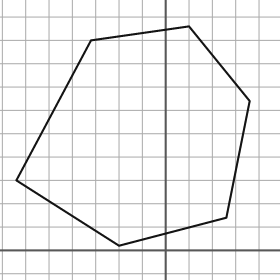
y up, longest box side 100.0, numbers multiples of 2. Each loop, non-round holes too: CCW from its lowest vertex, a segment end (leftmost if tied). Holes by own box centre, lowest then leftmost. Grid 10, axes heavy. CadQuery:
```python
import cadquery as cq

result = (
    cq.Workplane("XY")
    .moveTo(-20.0, 2.0)
    .lineTo(26.0, 14.0)
    .lineTo(36.0, 64.0)
    .lineTo(10.0, 96.0)
    .lineTo(-32.0, 90.0)
    .lineTo(-64.0, 30.0)
    .close()
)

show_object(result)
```